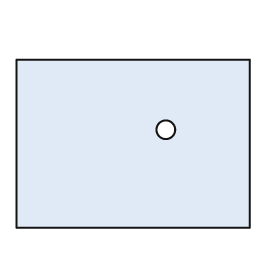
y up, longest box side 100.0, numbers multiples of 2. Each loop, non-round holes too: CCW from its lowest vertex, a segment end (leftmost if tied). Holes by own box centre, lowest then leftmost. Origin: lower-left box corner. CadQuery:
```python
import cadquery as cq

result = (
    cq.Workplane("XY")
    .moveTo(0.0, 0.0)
    .lineTo(100.0, 0.0)
    .lineTo(100.0, 72.0)
    .lineTo(0.0, 72.0)
    .close()
    .moveTo(64.0, 42.0)
    .circle(4.0)
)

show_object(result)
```